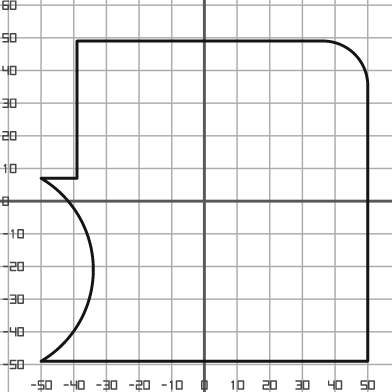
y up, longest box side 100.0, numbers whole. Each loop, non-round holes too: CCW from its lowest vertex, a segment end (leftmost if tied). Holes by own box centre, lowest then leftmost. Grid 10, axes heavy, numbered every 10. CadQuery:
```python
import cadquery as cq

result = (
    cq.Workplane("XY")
    .moveTo(-50.0, -49.0)
    .lineTo(50.0, -49.0)
    .lineTo(50.0, 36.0)
    .threePointArc((46.0, 45.0), (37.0, 49.0))
    .lineTo(-39.0, 49.0)
    .lineTo(-39.0, 7.0)
    .lineTo(-50.0, 7.0)
    .threePointArc((-34.0, -21.0), (-50.0, -49.0))
    .close()
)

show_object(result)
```